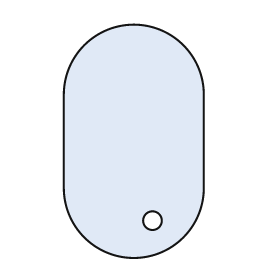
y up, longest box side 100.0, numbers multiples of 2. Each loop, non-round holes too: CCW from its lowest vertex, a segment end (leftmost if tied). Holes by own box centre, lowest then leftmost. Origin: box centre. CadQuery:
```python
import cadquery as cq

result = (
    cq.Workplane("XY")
    .moveTo(-30.0, -20.0)
    .threePointArc((0.0, -50.0), (30.0, -20.0))
    .lineTo(30.0, 20.0)
    .threePointArc((0.0, 50.0), (-30.0, 20.0))
    .close()
    .moveTo(8.0, -34.0)
    .circle(4.0)
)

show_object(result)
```